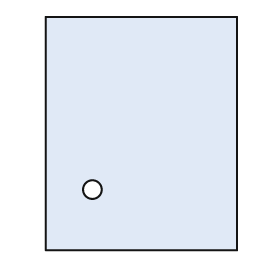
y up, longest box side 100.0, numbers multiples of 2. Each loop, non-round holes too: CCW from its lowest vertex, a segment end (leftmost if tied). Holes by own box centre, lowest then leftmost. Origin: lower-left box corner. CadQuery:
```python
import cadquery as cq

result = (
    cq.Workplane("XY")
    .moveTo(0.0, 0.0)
    .lineTo(82.0, 0.0)
    .lineTo(82.0, 100.0)
    .lineTo(0.0, 100.0)
    .close()
    .moveTo(20.0, 26.0)
    .circle(4.0)
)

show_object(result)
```